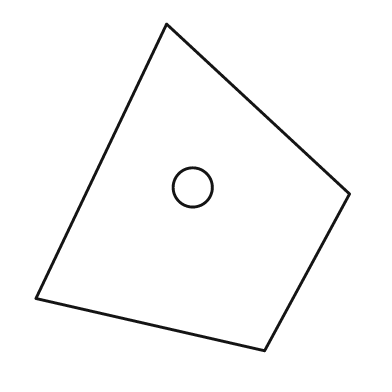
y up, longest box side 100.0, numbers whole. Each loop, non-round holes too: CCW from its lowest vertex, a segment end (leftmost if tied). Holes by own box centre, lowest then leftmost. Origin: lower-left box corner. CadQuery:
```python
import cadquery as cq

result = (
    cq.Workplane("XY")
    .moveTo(70.0, 0.0)
    .lineTo(96.0, 48.0)
    .lineTo(40.0, 100.0)
    .lineTo(0.0, 16.0)
    .close()
    .moveTo(48.0, 50.0)
    .circle(6.0)
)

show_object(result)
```